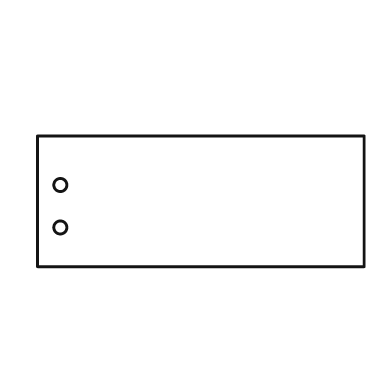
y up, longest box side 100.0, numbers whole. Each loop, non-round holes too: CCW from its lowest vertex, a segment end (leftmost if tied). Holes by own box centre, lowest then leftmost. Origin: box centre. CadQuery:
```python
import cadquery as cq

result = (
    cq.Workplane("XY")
    .moveTo(-50.0, -20.0)
    .lineTo(50.0, -20.0)
    .lineTo(50.0, 20.0)
    .lineTo(-50.0, 20.0)
    .close()
    .moveTo(-43.0, -8.0)
    .circle(2.0)
    .moveTo(-43.0, 5.0)
    .circle(2.0)
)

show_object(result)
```